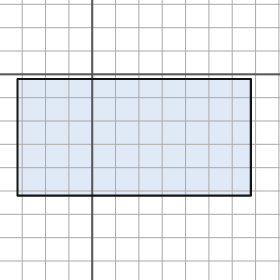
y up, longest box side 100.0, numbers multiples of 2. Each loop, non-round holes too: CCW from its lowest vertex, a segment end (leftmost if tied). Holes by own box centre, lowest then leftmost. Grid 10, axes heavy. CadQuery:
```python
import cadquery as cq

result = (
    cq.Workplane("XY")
    .moveTo(-32.0, -52.0)
    .lineTo(68.0, -52.0)
    .lineTo(68.0, -2.0)
    .lineTo(-32.0, -2.0)
    .close()
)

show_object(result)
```